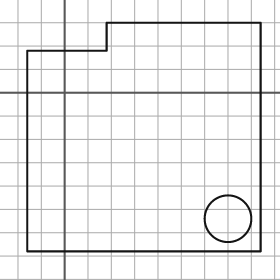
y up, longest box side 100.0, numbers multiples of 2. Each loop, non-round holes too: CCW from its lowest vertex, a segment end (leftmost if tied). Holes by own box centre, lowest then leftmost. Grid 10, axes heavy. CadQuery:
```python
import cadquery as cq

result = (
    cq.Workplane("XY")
    .moveTo(-16.0, -68.0)
    .lineTo(84.0, -68.0)
    .lineTo(84.0, 30.0)
    .lineTo(18.0, 30.0)
    .lineTo(18.0, 18.0)
    .lineTo(-16.0, 18.0)
    .close()
    .moveTo(70.0, -54.0)
    .circle(10.0)
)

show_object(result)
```